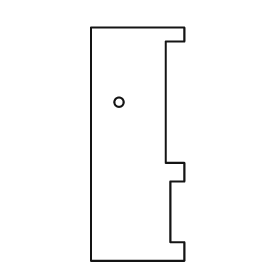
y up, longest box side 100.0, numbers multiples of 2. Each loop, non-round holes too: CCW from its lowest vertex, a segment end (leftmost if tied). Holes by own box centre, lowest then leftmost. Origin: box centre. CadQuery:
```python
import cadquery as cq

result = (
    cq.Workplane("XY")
    .moveTo(-20.0, -50.0)
    .lineTo(20.0, -50.0)
    .lineTo(20.0, -42.0)
    .lineTo(14.0, -42.0)
    .lineTo(14.0, -16.0)
    .lineTo(20.0, -16.0)
    .lineTo(20.0, -8.0)
    .lineTo(12.0, -8.0)
    .lineTo(12.0, 44.0)
    .lineTo(20.0, 44.0)
    .lineTo(20.0, 50.0)
    .lineTo(-20.0, 50.0)
    .close()
    .moveTo(-8.0, 18.0)
    .circle(2.0)
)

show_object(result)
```